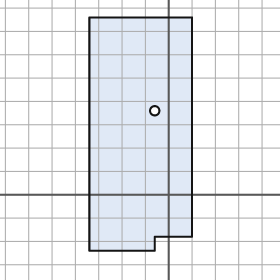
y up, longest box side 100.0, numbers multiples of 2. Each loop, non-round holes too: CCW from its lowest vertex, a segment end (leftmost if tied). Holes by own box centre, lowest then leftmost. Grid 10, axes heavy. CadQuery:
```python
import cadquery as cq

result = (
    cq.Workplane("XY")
    .moveTo(-34.0, -24.0)
    .lineTo(-6.0, -24.0)
    .lineTo(-6.0, -18.0)
    .lineTo(10.0, -18.0)
    .lineTo(10.0, 76.0)
    .lineTo(-34.0, 76.0)
    .close()
    .moveTo(-6.0, 36.0)
    .circle(2.0)
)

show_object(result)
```